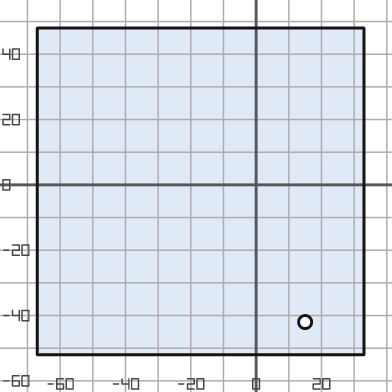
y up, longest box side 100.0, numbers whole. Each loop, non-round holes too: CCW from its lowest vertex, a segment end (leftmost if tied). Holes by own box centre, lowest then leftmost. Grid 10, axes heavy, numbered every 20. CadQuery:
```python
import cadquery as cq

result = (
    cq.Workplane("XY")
    .moveTo(-67.0, -52.0)
    .lineTo(33.0, -52.0)
    .lineTo(33.0, 48.0)
    .lineTo(-67.0, 48.0)
    .close()
    .moveTo(15.0, -42.0)
    .circle(2.0)
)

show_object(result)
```